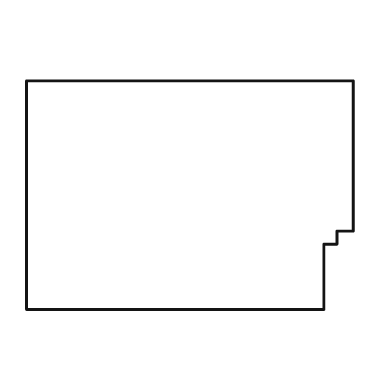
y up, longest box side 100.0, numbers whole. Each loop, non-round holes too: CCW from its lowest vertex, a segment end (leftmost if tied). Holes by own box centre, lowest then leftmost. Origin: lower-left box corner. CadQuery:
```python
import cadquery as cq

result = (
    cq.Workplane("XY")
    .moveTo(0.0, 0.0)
    .lineTo(91.0, 0.0)
    .lineTo(91.0, 20.0)
    .lineTo(95.0, 20.0)
    .lineTo(95.0, 24.0)
    .lineTo(100.0, 24.0)
    .lineTo(100.0, 70.0)
    .lineTo(0.0, 70.0)
    .close()
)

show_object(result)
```